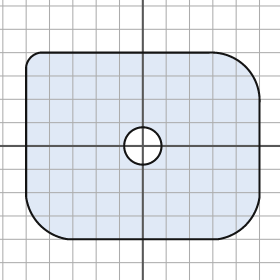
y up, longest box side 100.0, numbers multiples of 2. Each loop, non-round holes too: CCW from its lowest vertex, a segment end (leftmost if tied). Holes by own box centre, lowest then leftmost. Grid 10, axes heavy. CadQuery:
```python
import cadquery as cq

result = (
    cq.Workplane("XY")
    .moveTo(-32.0, -40.0)
    .lineTo(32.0, -40.0)
    .threePointArc((44.0, -34.0), (50.0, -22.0))
    .lineTo(50.0, 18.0)
    .threePointArc((44.0, 34.0), (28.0, 40.0))
    .lineTo(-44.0, 40.0)
    .threePointArc((-48.0, 38.0), (-50.0, 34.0))
    .lineTo(-50.0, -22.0)
    .threePointArc((-44.0, -34.0), (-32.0, -40.0))
    .close()
    .moveTo(0.0, 0.0)
    .circle(8.0)
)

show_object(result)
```